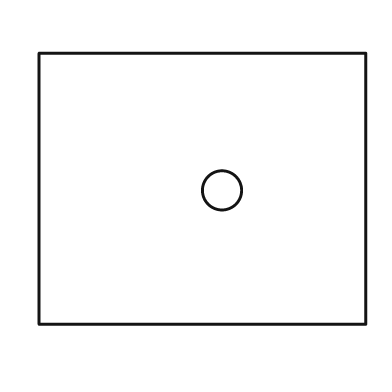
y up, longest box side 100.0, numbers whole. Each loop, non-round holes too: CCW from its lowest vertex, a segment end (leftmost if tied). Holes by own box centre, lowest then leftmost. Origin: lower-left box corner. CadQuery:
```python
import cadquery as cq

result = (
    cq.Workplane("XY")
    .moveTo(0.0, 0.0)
    .lineTo(100.0, 0.0)
    .lineTo(100.0, 83.0)
    .lineTo(0.0, 83.0)
    .close()
    .moveTo(56.0, 41.0)
    .circle(6.0)
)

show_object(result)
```